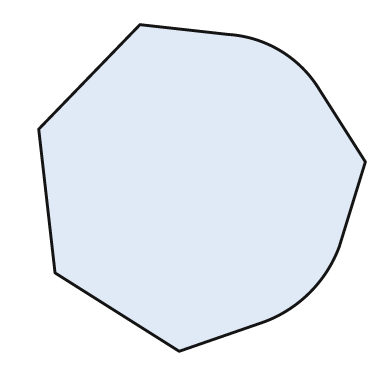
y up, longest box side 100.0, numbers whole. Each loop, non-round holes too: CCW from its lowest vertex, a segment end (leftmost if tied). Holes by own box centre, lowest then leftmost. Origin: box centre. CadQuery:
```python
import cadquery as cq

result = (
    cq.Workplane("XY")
    .moveTo(-7.0, -50.0)
    .lineTo(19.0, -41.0)
    .threePointArc((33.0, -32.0), (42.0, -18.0))
    .lineTo(50.0, 8.0)
    .lineTo(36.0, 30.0)
    .threePointArc((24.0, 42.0), (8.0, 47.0))
    .lineTo(-19.0, 50.0)
    .lineTo(-50.0, 18.0)
    .lineTo(-45.0, -26.0)
    .close()
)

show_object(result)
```